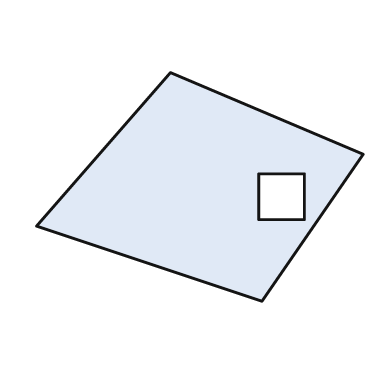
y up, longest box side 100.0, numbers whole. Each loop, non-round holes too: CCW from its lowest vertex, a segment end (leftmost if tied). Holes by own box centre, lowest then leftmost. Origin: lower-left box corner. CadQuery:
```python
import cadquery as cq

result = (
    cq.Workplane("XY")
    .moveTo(69.0, 0.0)
    .lineTo(100.0, 45.0)
    .lineTo(41.0, 70.0)
    .lineTo(0.0, 23.0)
    .close()
    .moveTo(68.0, 25.0)
    .lineTo(82.0, 25.0)
    .lineTo(82.0, 39.0)
    .lineTo(68.0, 39.0)
    .close()
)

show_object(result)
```